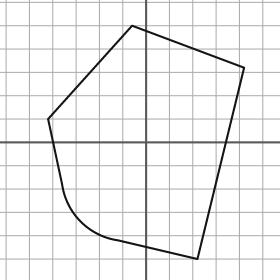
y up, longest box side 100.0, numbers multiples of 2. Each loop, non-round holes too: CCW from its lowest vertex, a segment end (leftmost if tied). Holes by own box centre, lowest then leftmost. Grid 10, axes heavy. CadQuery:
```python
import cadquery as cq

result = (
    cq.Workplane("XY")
    .moveTo(22.0, -50.0)
    .lineTo(42.0, 32.0)
    .lineTo(-6.0, 50.0)
    .lineTo(-42.0, 10.0)
    .lineTo(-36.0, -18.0)
    .threePointArc((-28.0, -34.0), (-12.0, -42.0))
    .close()
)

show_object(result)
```